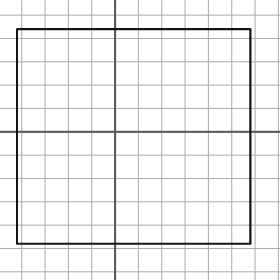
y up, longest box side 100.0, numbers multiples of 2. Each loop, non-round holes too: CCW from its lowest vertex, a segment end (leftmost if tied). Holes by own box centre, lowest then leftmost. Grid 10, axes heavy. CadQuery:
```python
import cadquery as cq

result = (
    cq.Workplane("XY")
    .moveTo(-42.0, -48.0)
    .lineTo(58.0, -48.0)
    .lineTo(58.0, 44.0)
    .lineTo(-42.0, 44.0)
    .close()
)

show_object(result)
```